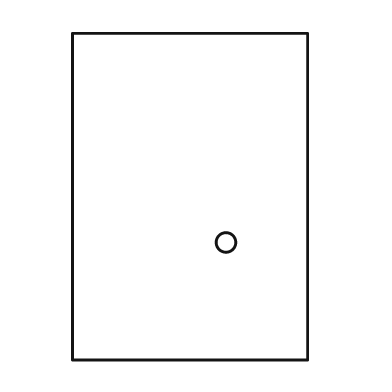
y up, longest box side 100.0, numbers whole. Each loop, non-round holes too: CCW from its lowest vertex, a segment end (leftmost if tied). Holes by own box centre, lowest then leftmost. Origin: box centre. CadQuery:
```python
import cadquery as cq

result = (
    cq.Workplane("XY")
    .moveTo(-36.0, -50.0)
    .lineTo(36.0, -50.0)
    .lineTo(36.0, 50.0)
    .lineTo(-36.0, 50.0)
    .close()
    .moveTo(11.0, -14.0)
    .circle(3.0)
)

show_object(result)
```